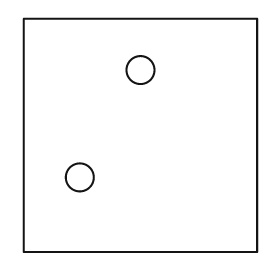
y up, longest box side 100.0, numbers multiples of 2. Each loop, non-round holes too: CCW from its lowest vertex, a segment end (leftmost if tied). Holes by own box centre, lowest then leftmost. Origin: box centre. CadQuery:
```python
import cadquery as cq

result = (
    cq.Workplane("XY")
    .moveTo(-50.0, -50.0)
    .lineTo(50.0, -50.0)
    .lineTo(50.0, 50.0)
    .lineTo(-50.0, 50.0)
    .close()
    .moveTo(-26.0, -18.0)
    .circle(6.0)
    .moveTo(0.0, 28.0)
    .circle(6.0)
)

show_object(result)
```